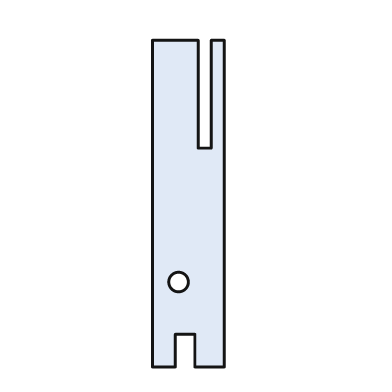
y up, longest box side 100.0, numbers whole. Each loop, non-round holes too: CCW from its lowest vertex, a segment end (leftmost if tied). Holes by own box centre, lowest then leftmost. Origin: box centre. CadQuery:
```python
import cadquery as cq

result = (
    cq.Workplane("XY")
    .moveTo(-11.0, -50.0)
    .lineTo(-4.0, -50.0)
    .lineTo(-4.0, -40.0)
    .lineTo(2.0, -40.0)
    .lineTo(2.0, -50.0)
    .lineTo(11.0, -50.0)
    .lineTo(11.0, 50.0)
    .lineTo(7.0, 50.0)
    .lineTo(7.0, 17.0)
    .lineTo(3.0, 17.0)
    .lineTo(3.0, 50.0)
    .lineTo(-11.0, 50.0)
    .close()
    .moveTo(-3.0, -24.0)
    .circle(3.0)
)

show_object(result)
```